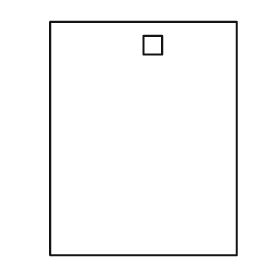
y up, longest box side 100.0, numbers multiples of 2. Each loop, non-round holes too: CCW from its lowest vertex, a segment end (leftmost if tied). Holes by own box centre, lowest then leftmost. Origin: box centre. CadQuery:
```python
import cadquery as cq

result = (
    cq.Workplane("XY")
    .moveTo(-40.0, -50.0)
    .lineTo(40.0, -50.0)
    .lineTo(40.0, 50.0)
    .lineTo(-40.0, 50.0)
    .close()
    .moveTo(0.0, 36.0)
    .lineTo(8.0, 36.0)
    .lineTo(8.0, 44.0)
    .lineTo(0.0, 44.0)
    .close()
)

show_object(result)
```